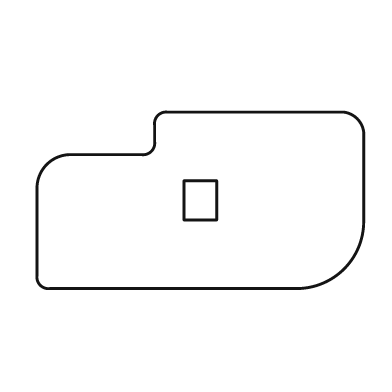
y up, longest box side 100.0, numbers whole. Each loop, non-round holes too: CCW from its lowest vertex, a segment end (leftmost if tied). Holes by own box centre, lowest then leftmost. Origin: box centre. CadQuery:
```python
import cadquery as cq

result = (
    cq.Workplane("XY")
    .moveTo(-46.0, -27.0)
    .lineTo(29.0, -27.0)
    .threePointArc((44.0, -21.0), (50.0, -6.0))
    .lineTo(50.0, 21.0)
    .threePointArc((48.0, 25.0), (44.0, 27.0))
    .lineTo(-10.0, 27.0)
    .threePointArc((-13.0, 26.0), (-14.0, 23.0))
    .lineTo(-14.0, 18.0)
    .threePointArc((-15.0, 15.0), (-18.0, 14.0))
    .lineTo(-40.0, 14.0)
    .threePointArc((-47.0, 11.0), (-50.0, 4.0))
    .lineTo(-50.0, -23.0)
    .threePointArc((-49.0, -26.0), (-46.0, -27.0))
    .close()
    .moveTo(-5.0, -6.0)
    .lineTo(5.0, -6.0)
    .lineTo(5.0, 6.0)
    .lineTo(-5.0, 6.0)
    .close()
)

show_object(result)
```